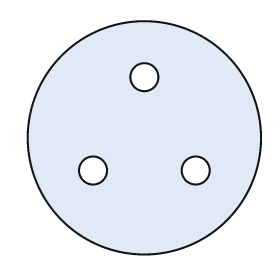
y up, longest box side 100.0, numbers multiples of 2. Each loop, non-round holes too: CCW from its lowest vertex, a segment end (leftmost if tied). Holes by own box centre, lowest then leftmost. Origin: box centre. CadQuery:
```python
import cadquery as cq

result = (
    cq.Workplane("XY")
    .moveTo(0.0, 0.0)
    .circle(50.0)
    .moveTo(-22.0, -14.0)
    .circle(6.0)
    .moveTo(22.0, -14.0)
    .circle(6.0)
    .moveTo(0.0, 26.0)
    .circle(6.0)
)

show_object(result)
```